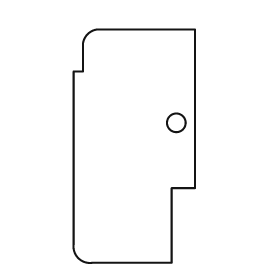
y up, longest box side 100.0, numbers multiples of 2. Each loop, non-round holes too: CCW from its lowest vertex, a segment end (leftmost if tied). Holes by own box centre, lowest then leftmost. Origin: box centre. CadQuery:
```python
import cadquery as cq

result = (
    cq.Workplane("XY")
    .moveTo(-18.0, -50.0)
    .lineTo(16.0, -50.0)
    .lineTo(16.0, -18.0)
    .lineTo(26.0, -18.0)
    .lineTo(26.0, 50.0)
    .lineTo(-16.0, 50.0)
    .threePointArc((-20.0, 48.0), (-22.0, 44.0))
    .lineTo(-22.0, 32.0)
    .lineTo(-26.0, 32.0)
    .lineTo(-26.0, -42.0)
    .threePointArc((-24.0, -48.0), (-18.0, -50.0))
    .close()
    .moveTo(18.0, 10.0)
    .circle(4.0)
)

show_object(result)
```